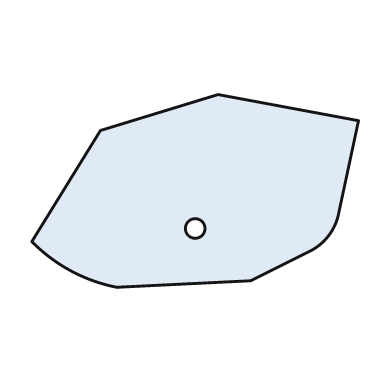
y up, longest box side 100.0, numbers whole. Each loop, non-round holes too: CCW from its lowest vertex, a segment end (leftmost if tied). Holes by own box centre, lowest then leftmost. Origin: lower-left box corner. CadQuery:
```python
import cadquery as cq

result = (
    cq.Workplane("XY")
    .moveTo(26.0, 0.0)
    .lineTo(67.0, 2.0)
    .lineTo(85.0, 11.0)
    .threePointArc((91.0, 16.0), (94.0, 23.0))
    .lineTo(100.0, 51.0)
    .lineTo(57.0, 59.0)
    .lineTo(21.0, 48.0)
    .lineTo(0.0, 14.0)
    .threePointArc((12.0, 5.0), (26.0, 0.0))
    .close()
    .moveTo(50.0, 18.0)
    .circle(3.0)
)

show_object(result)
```